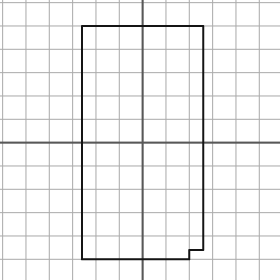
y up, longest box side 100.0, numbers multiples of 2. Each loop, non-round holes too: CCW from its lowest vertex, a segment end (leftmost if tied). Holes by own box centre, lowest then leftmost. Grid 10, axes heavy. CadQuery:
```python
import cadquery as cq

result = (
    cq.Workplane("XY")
    .moveTo(-26.0, -50.0)
    .lineTo(20.0, -50.0)
    .lineTo(20.0, -46.0)
    .lineTo(26.0, -46.0)
    .lineTo(26.0, 50.0)
    .lineTo(-26.0, 50.0)
    .close()
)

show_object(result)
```